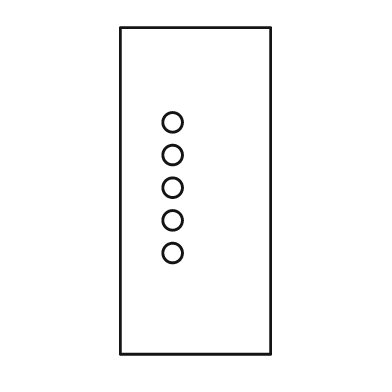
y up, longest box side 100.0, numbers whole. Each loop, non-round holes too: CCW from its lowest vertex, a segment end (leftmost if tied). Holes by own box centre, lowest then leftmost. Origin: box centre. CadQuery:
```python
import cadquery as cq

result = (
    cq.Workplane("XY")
    .moveTo(-23.0, -50.0)
    .lineTo(23.0, -50.0)
    .lineTo(23.0, 50.0)
    .lineTo(-23.0, 50.0)
    .close()
    .moveTo(-7.0, -19.0)
    .circle(3.0)
    .moveTo(-7.0, -9.0)
    .circle(3.0)
    .moveTo(-7.0, 1.0)
    .circle(3.0)
    .moveTo(-7.0, 11.0)
    .circle(3.0)
    .moveTo(-7.0, 21.0)
    .circle(3.0)
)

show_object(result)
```